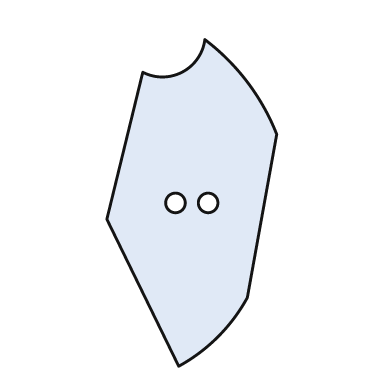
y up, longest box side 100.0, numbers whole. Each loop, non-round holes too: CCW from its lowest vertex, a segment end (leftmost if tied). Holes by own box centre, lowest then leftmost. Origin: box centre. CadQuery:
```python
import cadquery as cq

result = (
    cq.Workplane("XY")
    .moveTo(-4.0, -50.0)
    .threePointArc((8.0, -41.0), (17.0, -29.0))
    .lineTo(26.0, 21.0)
    .threePointArc((17.0, 37.0), (4.0, 50.0))
    .threePointArc((-3.0, 40.0), (-15.0, 40.0))
    .lineTo(-26.0, -5.0)
    .close()
    .moveTo(-5.0, 0.0)
    .circle(3.0)
    .moveTo(5.0, 0.0)
    .circle(3.0)
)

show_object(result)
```